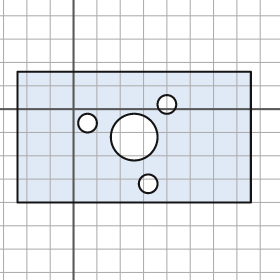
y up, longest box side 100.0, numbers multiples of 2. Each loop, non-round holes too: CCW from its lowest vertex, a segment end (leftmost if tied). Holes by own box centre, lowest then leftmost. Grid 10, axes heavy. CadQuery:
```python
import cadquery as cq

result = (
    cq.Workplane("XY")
    .moveTo(-24.0, -40.0)
    .lineTo(76.0, -40.0)
    .lineTo(76.0, 16.0)
    .lineTo(-24.0, 16.0)
    .close()
    .moveTo(32.0, -32.0)
    .circle(4.0)
    .moveTo(26.0, -12.0)
    .circle(10.0)
    .moveTo(6.0, -6.0)
    .circle(4.0)
    .moveTo(40.0, 2.0)
    .circle(4.0)
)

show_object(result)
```